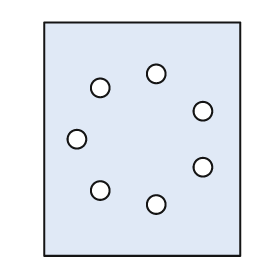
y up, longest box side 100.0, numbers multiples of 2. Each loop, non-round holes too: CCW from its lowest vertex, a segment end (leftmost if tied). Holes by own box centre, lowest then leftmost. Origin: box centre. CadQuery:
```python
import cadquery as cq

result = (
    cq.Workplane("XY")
    .moveTo(-42.0, -50.0)
    .lineTo(42.0, -50.0)
    .lineTo(42.0, 50.0)
    .lineTo(-42.0, 50.0)
    .close()
    .moveTo(6.0, -28.0)
    .circle(4.0)
    .moveTo(-18.0, -22.0)
    .circle(4.0)
    .moveTo(26.0, -12.0)
    .circle(4.0)
    .moveTo(-28.0, 0.0)
    .circle(4.0)
    .moveTo(26.0, 12.0)
    .circle(4.0)
    .moveTo(-18.0, 22.0)
    .circle(4.0)
    .moveTo(6.0, 28.0)
    .circle(4.0)
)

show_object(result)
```